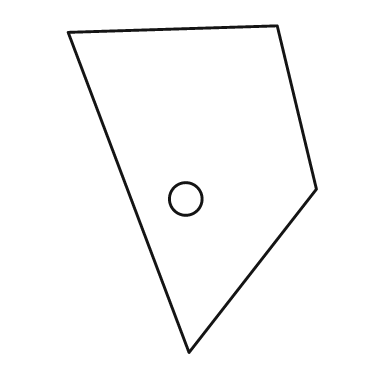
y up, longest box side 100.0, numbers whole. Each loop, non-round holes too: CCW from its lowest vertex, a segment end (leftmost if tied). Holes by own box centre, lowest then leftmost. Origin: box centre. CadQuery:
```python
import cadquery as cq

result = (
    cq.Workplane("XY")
    .moveTo(-1.0, -50.0)
    .lineTo(38.0, 0.0)
    .lineTo(26.0, 50.0)
    .lineTo(-38.0, 48.0)
    .close()
    .moveTo(-2.0, -3.0)
    .circle(5.0)
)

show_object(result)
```